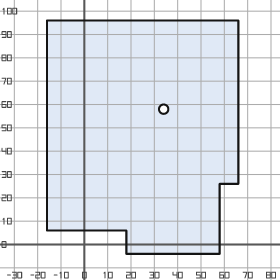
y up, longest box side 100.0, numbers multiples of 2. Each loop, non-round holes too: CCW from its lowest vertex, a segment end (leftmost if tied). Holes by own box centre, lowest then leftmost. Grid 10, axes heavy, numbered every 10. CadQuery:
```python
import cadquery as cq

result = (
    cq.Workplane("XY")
    .moveTo(18.0, -4.0)
    .lineTo(58.0, -4.0)
    .lineTo(58.0, 26.0)
    .lineTo(66.0, 26.0)
    .lineTo(66.0, 96.0)
    .lineTo(-16.0, 96.0)
    .lineTo(-16.0, 6.0)
    .lineTo(18.0, 6.0)
    .close()
    .moveTo(34.0, 58.0)
    .circle(2.0)
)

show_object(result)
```